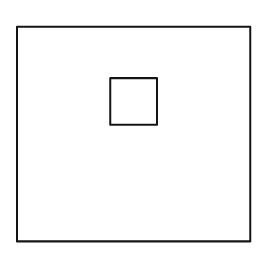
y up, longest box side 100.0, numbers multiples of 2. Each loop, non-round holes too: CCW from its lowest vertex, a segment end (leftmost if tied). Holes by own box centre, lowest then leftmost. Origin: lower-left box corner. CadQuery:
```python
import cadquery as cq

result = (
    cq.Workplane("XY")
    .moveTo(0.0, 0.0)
    .lineTo(100.0, 0.0)
    .lineTo(100.0, 92.0)
    .lineTo(0.0, 92.0)
    .close()
    .moveTo(40.0, 50.0)
    .lineTo(60.0, 50.0)
    .lineTo(60.0, 70.0)
    .lineTo(40.0, 70.0)
    .close()
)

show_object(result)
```